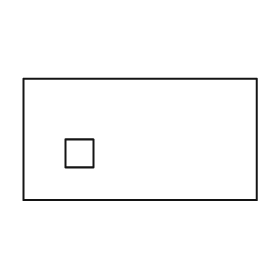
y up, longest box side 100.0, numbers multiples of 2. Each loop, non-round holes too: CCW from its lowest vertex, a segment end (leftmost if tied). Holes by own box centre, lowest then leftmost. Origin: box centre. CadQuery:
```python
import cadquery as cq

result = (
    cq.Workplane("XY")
    .moveTo(-50.0, -26.0)
    .lineTo(50.0, -26.0)
    .lineTo(50.0, 26.0)
    .lineTo(-50.0, 26.0)
    .close()
    .moveTo(-32.0, -12.0)
    .lineTo(-20.0, -12.0)
    .lineTo(-20.0, 0.0)
    .lineTo(-32.0, 0.0)
    .close()
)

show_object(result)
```